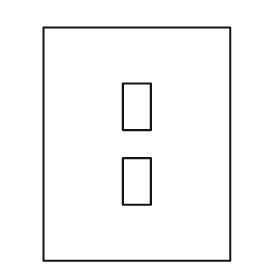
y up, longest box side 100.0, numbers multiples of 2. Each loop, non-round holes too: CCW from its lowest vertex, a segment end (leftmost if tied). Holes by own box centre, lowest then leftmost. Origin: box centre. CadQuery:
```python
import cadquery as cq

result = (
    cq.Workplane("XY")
    .moveTo(-40.0, -50.0)
    .lineTo(40.0, -50.0)
    .lineTo(40.0, 50.0)
    .lineTo(-40.0, 50.0)
    .close()
    .moveTo(-6.0, -26.0)
    .lineTo(6.0, -26.0)
    .lineTo(6.0, -6.0)
    .lineTo(-6.0, -6.0)
    .close()
    .moveTo(-6.0, 6.0)
    .lineTo(6.0, 6.0)
    .lineTo(6.0, 26.0)
    .lineTo(-6.0, 26.0)
    .close()
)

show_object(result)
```